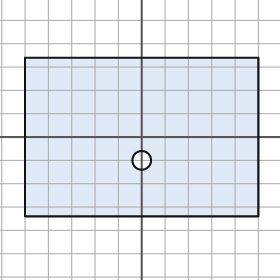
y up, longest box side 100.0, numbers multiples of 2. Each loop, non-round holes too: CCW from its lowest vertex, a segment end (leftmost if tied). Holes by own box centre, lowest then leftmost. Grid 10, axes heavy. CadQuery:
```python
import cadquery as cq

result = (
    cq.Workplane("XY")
    .moveTo(-50.0, -34.0)
    .lineTo(50.0, -34.0)
    .lineTo(50.0, 34.0)
    .lineTo(-50.0, 34.0)
    .close()
    .moveTo(0.0, -10.0)
    .circle(4.0)
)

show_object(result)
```